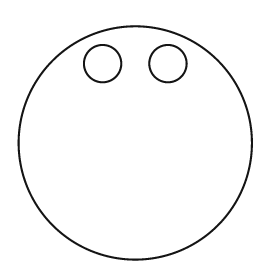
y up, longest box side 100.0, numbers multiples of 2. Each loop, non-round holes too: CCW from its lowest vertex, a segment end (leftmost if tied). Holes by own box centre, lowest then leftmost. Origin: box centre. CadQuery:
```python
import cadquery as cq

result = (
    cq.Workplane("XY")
    .moveTo(0.0, 0.0)
    .circle(50.0)
    .moveTo(-14.0, 34.0)
    .circle(8.0)
    .moveTo(14.0, 34.0)
    .circle(8.0)
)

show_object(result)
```